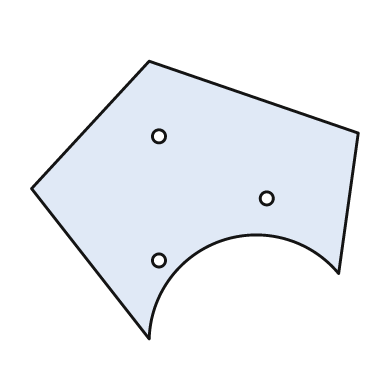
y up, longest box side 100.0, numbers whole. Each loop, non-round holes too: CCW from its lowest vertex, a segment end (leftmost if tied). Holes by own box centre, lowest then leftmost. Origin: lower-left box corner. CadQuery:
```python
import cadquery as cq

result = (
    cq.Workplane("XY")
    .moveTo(36.0, 0.0)
    .threePointArc((58.0, 30.0), (94.0, 20.0))
    .lineTo(100.0, 63.0)
    .lineTo(36.0, 85.0)
    .lineTo(0.0, 46.0)
    .close()
    .moveTo(39.0, 24.0)
    .circle(2.0)
    .moveTo(72.0, 43.0)
    .circle(2.0)
    .moveTo(39.0, 62.0)
    .circle(2.0)
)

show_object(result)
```